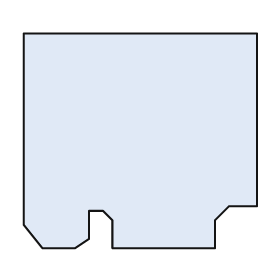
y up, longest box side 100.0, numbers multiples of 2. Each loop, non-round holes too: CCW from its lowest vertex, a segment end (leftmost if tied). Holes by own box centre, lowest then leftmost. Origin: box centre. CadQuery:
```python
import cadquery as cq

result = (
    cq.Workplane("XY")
    .moveTo(-42.0, -46.0)
    .lineTo(-28.0, -46.0)
    .lineTo(-22.0, -42.0)
    .lineTo(-22.0, -30.0)
    .lineTo(-16.0, -30.0)
    .lineTo(-12.0, -34.0)
    .lineTo(-12.0, -46.0)
    .lineTo(32.0, -46.0)
    .lineTo(32.0, -34.0)
    .lineTo(38.0, -28.0)
    .lineTo(50.0, -28.0)
    .lineTo(50.0, 46.0)
    .lineTo(-50.0, 46.0)
    .lineTo(-50.0, -36.0)
    .close()
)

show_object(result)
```